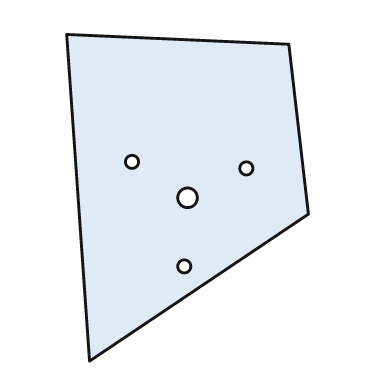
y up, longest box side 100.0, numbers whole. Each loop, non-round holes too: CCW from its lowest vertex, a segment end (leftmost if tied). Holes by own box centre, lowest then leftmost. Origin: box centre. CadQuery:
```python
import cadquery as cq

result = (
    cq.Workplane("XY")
    .moveTo(-30.0, -50.0)
    .lineTo(37.0, -5.0)
    .lineTo(31.0, 47.0)
    .lineTo(-37.0, 50.0)
    .close()
    .moveTo(-1.0, -21.0)
    .circle(2.0)
    .moveTo(0.0, 0.0)
    .circle(3.0)
    .moveTo(18.0, 9.0)
    .circle(2.0)
    .moveTo(-17.0, 11.0)
    .circle(2.0)
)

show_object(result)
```